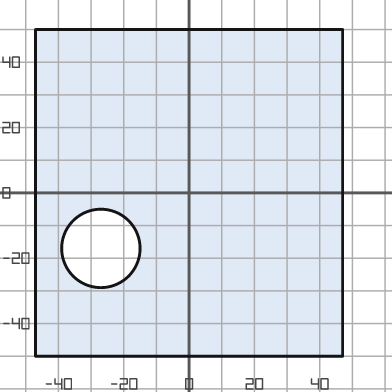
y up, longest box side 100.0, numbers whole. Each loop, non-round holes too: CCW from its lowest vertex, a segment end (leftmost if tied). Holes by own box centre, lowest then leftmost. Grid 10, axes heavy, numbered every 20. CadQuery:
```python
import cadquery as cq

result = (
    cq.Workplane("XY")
    .moveTo(-47.0, -50.0)
    .lineTo(47.0, -50.0)
    .lineTo(47.0, 50.0)
    .lineTo(-47.0, 50.0)
    .close()
    .moveTo(-27.0, -17.0)
    .circle(12.0)
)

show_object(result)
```